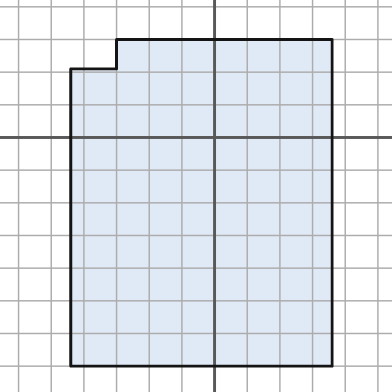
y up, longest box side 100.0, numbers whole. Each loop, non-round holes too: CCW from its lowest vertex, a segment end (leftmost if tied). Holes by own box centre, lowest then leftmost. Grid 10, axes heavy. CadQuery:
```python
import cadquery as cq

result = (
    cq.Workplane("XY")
    .moveTo(-44.0, -70.0)
    .lineTo(36.0, -70.0)
    .lineTo(36.0, 30.0)
    .lineTo(-30.0, 30.0)
    .lineTo(-30.0, 21.0)
    .lineTo(-44.0, 21.0)
    .close()
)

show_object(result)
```